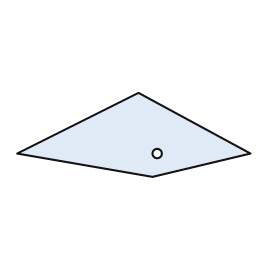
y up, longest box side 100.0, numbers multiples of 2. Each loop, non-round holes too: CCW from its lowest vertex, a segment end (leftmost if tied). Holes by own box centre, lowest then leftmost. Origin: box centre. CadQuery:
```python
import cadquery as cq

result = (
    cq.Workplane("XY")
    .moveTo(8.0, -18.0)
    .lineTo(50.0, -8.0)
    .lineTo(2.0, 18.0)
    .lineTo(-50.0, -8.0)
    .close()
    .moveTo(10.0, -8.0)
    .circle(2.0)
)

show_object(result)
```